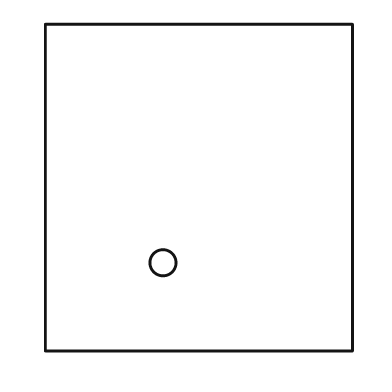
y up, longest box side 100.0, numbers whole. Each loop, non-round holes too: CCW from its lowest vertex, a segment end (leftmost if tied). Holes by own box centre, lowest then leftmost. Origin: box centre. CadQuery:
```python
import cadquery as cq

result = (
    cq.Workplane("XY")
    .moveTo(-47.0, -50.0)
    .lineTo(47.0, -50.0)
    .lineTo(47.0, 50.0)
    .lineTo(-47.0, 50.0)
    .close()
    .moveTo(-11.0, -23.0)
    .circle(4.0)
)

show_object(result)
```